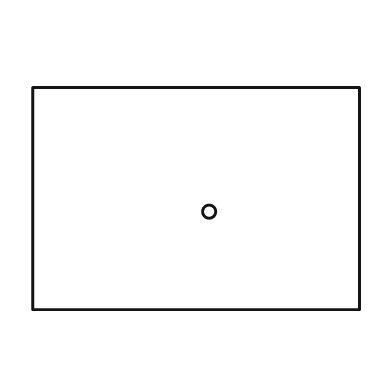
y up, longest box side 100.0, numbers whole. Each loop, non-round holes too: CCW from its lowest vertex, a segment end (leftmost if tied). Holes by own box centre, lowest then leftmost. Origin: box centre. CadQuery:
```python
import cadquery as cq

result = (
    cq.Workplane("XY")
    .moveTo(-50.0, -34.0)
    .lineTo(50.0, -34.0)
    .lineTo(50.0, 34.0)
    .lineTo(-50.0, 34.0)
    .close()
    .moveTo(4.0, -4.0)
    .circle(2.0)
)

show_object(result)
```